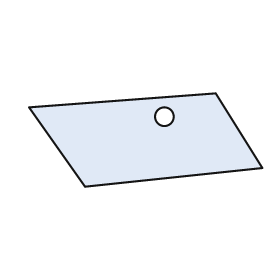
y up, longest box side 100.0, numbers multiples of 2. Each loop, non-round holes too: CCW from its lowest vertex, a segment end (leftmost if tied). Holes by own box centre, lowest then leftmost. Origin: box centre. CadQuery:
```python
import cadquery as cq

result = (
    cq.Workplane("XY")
    .moveTo(-26.0, -20.0)
    .lineTo(50.0, -12.0)
    .lineTo(30.0, 20.0)
    .lineTo(-50.0, 14.0)
    .close()
    .moveTo(8.0, 10.0)
    .circle(4.0)
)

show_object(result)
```